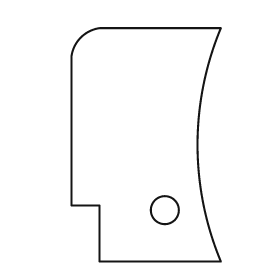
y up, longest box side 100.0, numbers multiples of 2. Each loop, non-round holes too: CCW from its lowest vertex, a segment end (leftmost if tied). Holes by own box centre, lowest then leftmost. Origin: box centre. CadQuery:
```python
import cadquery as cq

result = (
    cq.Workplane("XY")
    .moveTo(-20.0, -50.0)
    .lineTo(32.0, -50.0)
    .threePointArc((22.0, 0.0), (32.0, 50.0))
    .lineTo(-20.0, 50.0)
    .threePointArc((-28.0, 46.0), (-32.0, 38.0))
    .lineTo(-32.0, -26.0)
    .lineTo(-20.0, -26.0)
    .close()
    .moveTo(8.0, -28.0)
    .circle(6.0)
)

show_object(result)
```